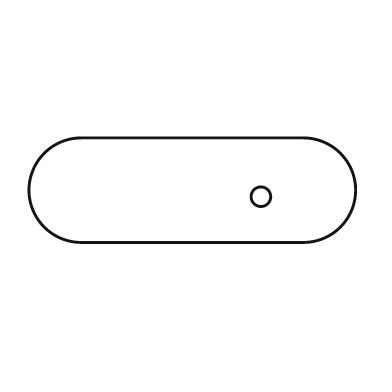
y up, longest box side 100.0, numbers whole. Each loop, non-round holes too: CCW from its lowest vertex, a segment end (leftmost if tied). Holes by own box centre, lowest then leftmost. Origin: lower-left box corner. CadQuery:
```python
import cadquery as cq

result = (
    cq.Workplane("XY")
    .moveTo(16.0, 0.0)
    .lineTo(84.0, 0.0)
    .threePointArc((100.0, 16.0), (84.0, 32.0))
    .lineTo(16.0, 32.0)
    .threePointArc((0.0, 16.0), (16.0, 0.0))
    .close()
    .moveTo(71.0, 14.0)
    .circle(3.0)
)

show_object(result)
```